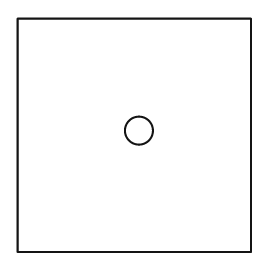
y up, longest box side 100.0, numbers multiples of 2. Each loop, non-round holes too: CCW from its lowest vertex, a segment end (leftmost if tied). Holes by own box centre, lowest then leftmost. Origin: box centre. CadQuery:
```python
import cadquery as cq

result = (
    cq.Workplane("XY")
    .moveTo(-50.0, -50.0)
    .lineTo(50.0, -50.0)
    .lineTo(50.0, 50.0)
    .lineTo(-50.0, 50.0)
    .close()
    .moveTo(2.0, 2.0)
    .circle(6.0)
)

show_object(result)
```